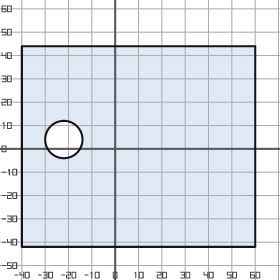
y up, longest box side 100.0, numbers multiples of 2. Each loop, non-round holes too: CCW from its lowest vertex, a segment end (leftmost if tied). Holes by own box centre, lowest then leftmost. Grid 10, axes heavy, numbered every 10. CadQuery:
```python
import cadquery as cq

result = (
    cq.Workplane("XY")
    .moveTo(-40.0, -42.0)
    .lineTo(60.0, -42.0)
    .lineTo(60.0, 44.0)
    .lineTo(-40.0, 44.0)
    .close()
    .moveTo(-22.0, 4.0)
    .circle(8.0)
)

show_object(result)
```